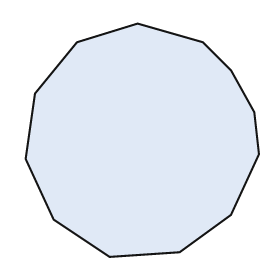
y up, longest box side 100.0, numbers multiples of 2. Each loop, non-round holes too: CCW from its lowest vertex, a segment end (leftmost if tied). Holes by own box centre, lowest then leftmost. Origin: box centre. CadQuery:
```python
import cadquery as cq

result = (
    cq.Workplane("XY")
    .moveTo(-14.0, -50.0)
    .lineTo(16.0, -48.0)
    .lineTo(38.0, -32.0)
    .lineTo(50.0, -6.0)
    .lineTo(48.0, 12.0)
    .lineTo(38.0, 30.0)
    .lineTo(26.0, 42.0)
    .lineTo(-2.0, 50.0)
    .lineTo(-28.0, 42.0)
    .lineTo(-46.0, 20.0)
    .lineTo(-50.0, -8.0)
    .lineTo(-38.0, -34.0)
    .close()
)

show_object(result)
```